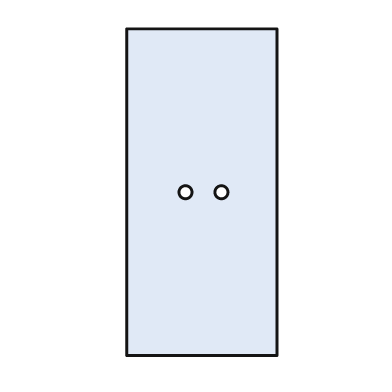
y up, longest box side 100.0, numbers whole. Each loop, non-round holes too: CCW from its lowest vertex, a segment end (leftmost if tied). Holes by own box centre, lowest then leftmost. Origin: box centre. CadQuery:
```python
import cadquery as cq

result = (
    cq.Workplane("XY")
    .moveTo(-23.0, -50.0)
    .lineTo(23.0, -50.0)
    .lineTo(23.0, 50.0)
    .lineTo(-23.0, 50.0)
    .close()
    .moveTo(-5.0, 0.0)
    .circle(2.0)
    .moveTo(6.0, 0.0)
    .circle(2.0)
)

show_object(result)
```